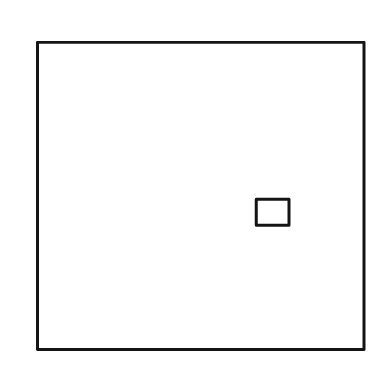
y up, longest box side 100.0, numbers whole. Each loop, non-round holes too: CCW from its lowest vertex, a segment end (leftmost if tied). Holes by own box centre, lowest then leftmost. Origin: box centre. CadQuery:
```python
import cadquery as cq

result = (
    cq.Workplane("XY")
    .moveTo(-50.0, -47.0)
    .lineTo(50.0, -47.0)
    .lineTo(50.0, 47.0)
    .lineTo(-50.0, 47.0)
    .close()
    .moveTo(17.0, -9.0)
    .lineTo(27.0, -9.0)
    .lineTo(27.0, -1.0)
    .lineTo(17.0, -1.0)
    .close()
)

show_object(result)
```